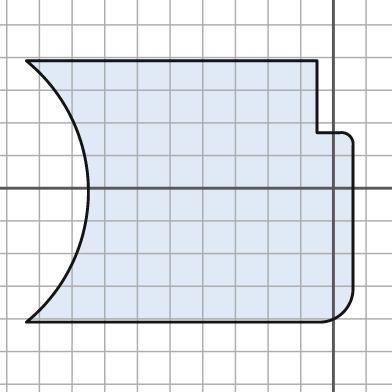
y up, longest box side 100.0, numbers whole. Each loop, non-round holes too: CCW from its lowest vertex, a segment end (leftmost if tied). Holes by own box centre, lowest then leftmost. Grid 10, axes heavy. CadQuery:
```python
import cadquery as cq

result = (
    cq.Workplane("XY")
    .moveTo(-94.0, -41.0)
    .lineTo(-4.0, -41.0)
    .threePointArc((3.0, -38.0), (6.0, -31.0))
    .lineTo(6.0, 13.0)
    .threePointArc((5.0, 16.0), (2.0, 17.0))
    .lineTo(-5.0, 17.0)
    .lineTo(-5.0, 39.0)
    .lineTo(-94.0, 39.0)
    .threePointArc((-75.0, -1.0), (-94.0, -41.0))
    .close()
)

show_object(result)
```